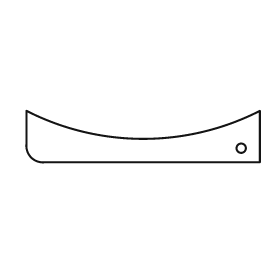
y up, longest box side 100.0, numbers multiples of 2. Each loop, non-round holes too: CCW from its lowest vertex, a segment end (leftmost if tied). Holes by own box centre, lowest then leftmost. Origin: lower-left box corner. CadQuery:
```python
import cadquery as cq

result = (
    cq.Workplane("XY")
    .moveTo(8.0, 0.0)
    .lineTo(100.0, 0.0)
    .lineTo(100.0, 22.0)
    .threePointArc((50.0, 10.0), (0.0, 22.0))
    .lineTo(0.0, 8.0)
    .threePointArc((2.0, 2.0), (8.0, 0.0))
    .close()
    .moveTo(92.0, 6.0)
    .circle(2.0)
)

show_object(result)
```